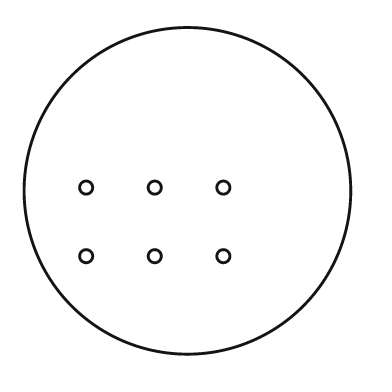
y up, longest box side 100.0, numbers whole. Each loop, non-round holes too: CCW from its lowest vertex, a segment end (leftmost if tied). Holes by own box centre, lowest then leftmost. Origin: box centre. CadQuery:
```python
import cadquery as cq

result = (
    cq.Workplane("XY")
    .moveTo(0.0, 0.0)
    .circle(50.0)
    .moveTo(-31.0, -20.0)
    .circle(2.0)
    .moveTo(-10.0, -20.0)
    .circle(2.0)
    .moveTo(11.0, -20.0)
    .circle(2.0)
    .moveTo(-31.0, 1.0)
    .circle(2.0)
    .moveTo(-10.0, 1.0)
    .circle(2.0)
    .moveTo(11.0, 1.0)
    .circle(2.0)
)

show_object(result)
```